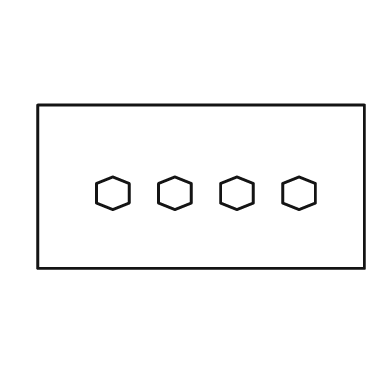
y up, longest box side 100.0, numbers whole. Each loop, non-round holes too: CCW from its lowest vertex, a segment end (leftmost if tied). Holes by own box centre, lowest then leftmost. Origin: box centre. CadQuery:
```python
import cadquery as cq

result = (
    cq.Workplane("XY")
    .moveTo(-50.0, -25.0)
    .lineTo(50.0, -25.0)
    .lineTo(50.0, 25.0)
    .lineTo(-50.0, 25.0)
    .close()
    .moveTo(-27.0, -7.0)
    .lineTo(-22.0, -5.0)
    .lineTo(-22.0, 1.0)
    .lineTo(-27.0, 3.0)
    .lineTo(-32.0, 1.0)
    .lineTo(-32.0, -5.0)
    .close()
    .moveTo(-8.0, -7.0)
    .lineTo(-3.0, -5.0)
    .lineTo(-3.0, 1.0)
    .lineTo(-8.0, 3.0)
    .lineTo(-13.0, 1.0)
    .lineTo(-13.0, -5.0)
    .close()
    .moveTo(11.0, -7.0)
    .lineTo(16.0, -5.0)
    .lineTo(16.0, 1.0)
    .lineTo(11.0, 3.0)
    .lineTo(6.0, 1.0)
    .lineTo(6.0, -5.0)
    .close()
    .moveTo(30.0, -7.0)
    .lineTo(35.0, -5.0)
    .lineTo(35.0, 1.0)
    .lineTo(30.0, 3.0)
    .lineTo(25.0, 1.0)
    .lineTo(25.0, -5.0)
    .close()
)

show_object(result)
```